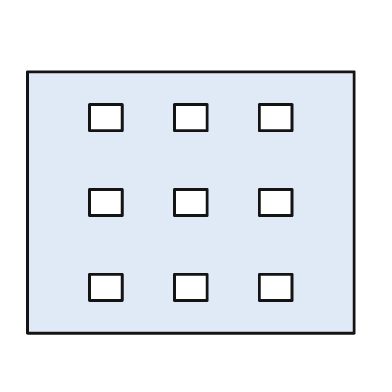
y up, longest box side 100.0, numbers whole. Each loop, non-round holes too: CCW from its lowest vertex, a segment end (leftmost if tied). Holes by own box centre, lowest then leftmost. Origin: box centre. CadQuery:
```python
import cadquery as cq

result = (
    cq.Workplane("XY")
    .moveTo(-50.0, -40.0)
    .lineTo(50.0, -40.0)
    .lineTo(50.0, 40.0)
    .lineTo(-50.0, 40.0)
    .close()
    .moveTo(-31.0, -30.0)
    .lineTo(-21.0, -30.0)
    .lineTo(-21.0, -22.0)
    .lineTo(-31.0, -22.0)
    .close()
    .moveTo(-5.0, -30.0)
    .lineTo(5.0, -30.0)
    .lineTo(5.0, -22.0)
    .lineTo(-5.0, -22.0)
    .close()
    .moveTo(21.0, -30.0)
    .lineTo(31.0, -30.0)
    .lineTo(31.0, -22.0)
    .lineTo(21.0, -22.0)
    .close()
    .moveTo(-31.0, -4.0)
    .lineTo(-21.0, -4.0)
    .lineTo(-21.0, 4.0)
    .lineTo(-31.0, 4.0)
    .close()
    .moveTo(-5.0, -4.0)
    .lineTo(5.0, -4.0)
    .lineTo(5.0, 4.0)
    .lineTo(-5.0, 4.0)
    .close()
    .moveTo(21.0, -4.0)
    .lineTo(31.0, -4.0)
    .lineTo(31.0, 4.0)
    .lineTo(21.0, 4.0)
    .close()
    .moveTo(-31.0, 22.0)
    .lineTo(-21.0, 22.0)
    .lineTo(-21.0, 30.0)
    .lineTo(-31.0, 30.0)
    .close()
    .moveTo(-5.0, 22.0)
    .lineTo(5.0, 22.0)
    .lineTo(5.0, 30.0)
    .lineTo(-5.0, 30.0)
    .close()
    .moveTo(21.0, 22.0)
    .lineTo(31.0, 22.0)
    .lineTo(31.0, 30.0)
    .lineTo(21.0, 30.0)
    .close()
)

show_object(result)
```